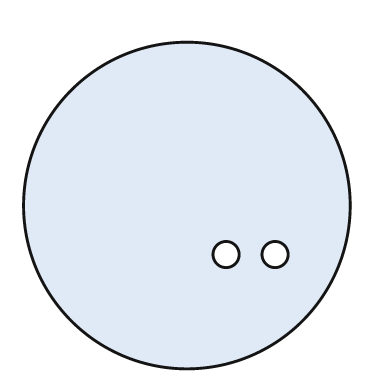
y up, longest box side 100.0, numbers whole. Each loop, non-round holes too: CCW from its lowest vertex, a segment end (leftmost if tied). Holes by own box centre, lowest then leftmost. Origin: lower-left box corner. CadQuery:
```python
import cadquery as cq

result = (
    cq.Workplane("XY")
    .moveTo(50.0, 50.0)
    .circle(50.0)
    .moveTo(62.0, 35.0)
    .circle(4.0)
    .moveTo(77.0, 35.0)
    .circle(4.0)
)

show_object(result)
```